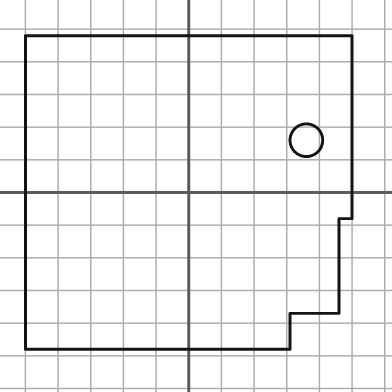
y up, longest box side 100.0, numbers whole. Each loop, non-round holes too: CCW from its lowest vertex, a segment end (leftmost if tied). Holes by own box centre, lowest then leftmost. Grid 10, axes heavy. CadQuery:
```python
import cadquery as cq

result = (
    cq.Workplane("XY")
    .moveTo(-50.0, -48.0)
    .lineTo(31.0, -48.0)
    .lineTo(31.0, -37.0)
    .lineTo(46.0, -37.0)
    .lineTo(46.0, -8.0)
    .lineTo(50.0, -8.0)
    .lineTo(50.0, 48.0)
    .lineTo(-50.0, 48.0)
    .close()
    .moveTo(36.0, 16.0)
    .circle(5.0)
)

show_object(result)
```